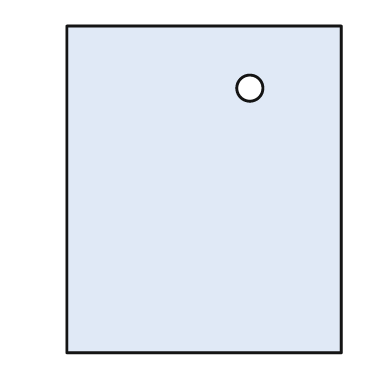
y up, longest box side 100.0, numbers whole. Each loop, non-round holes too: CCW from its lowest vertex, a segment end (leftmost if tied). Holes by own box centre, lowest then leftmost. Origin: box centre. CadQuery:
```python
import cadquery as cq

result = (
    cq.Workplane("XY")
    .moveTo(-42.0, -50.0)
    .lineTo(42.0, -50.0)
    .lineTo(42.0, 50.0)
    .lineTo(-42.0, 50.0)
    .close()
    .moveTo(14.0, 31.0)
    .circle(4.0)
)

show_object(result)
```